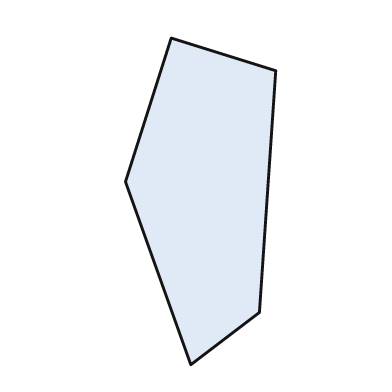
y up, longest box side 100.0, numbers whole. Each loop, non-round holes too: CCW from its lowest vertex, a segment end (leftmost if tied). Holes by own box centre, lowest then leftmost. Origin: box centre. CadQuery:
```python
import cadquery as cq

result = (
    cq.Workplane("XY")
    .moveTo(-3.0, -50.0)
    .lineTo(18.0, -34.0)
    .lineTo(23.0, 40.0)
    .lineTo(-9.0, 50.0)
    .lineTo(-23.0, 6.0)
    .close()
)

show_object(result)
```